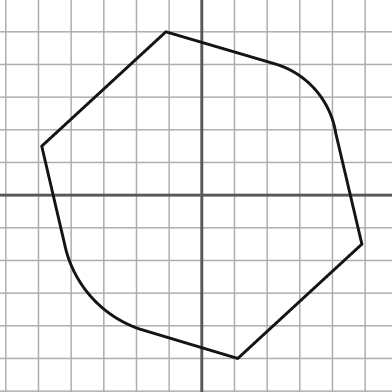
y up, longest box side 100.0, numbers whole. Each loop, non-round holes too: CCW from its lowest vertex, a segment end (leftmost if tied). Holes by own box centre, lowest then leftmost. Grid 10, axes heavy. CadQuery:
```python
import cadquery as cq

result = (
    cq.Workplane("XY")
    .moveTo(11.0, -50.0)
    .lineTo(49.0, -15.0)
    .lineTo(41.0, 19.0)
    .threePointArc((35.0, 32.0), (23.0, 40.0))
    .lineTo(-11.0, 50.0)
    .lineTo(-49.0, 15.0)
    .lineTo(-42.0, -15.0)
    .threePointArc((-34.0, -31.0), (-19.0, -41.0))
    .close()
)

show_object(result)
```